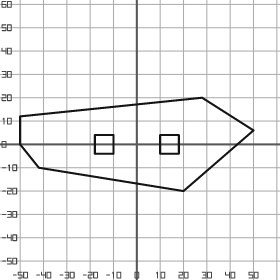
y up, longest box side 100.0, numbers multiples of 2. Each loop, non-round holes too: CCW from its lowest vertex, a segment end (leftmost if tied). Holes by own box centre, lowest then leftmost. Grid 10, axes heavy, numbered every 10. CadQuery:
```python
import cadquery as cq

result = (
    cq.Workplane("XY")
    .moveTo(20.0, -20.0)
    .lineTo(50.0, 6.0)
    .lineTo(28.0, 20.0)
    .lineTo(-50.0, 12.0)
    .lineTo(-50.0, 0.0)
    .lineTo(-42.0, -10.0)
    .close()
    .moveTo(-18.0, -4.0)
    .lineTo(-10.0, -4.0)
    .lineTo(-10.0, 4.0)
    .lineTo(-18.0, 4.0)
    .close()
    .moveTo(10.0, -4.0)
    .lineTo(18.0, -4.0)
    .lineTo(18.0, 4.0)
    .lineTo(10.0, 4.0)
    .close()
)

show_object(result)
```